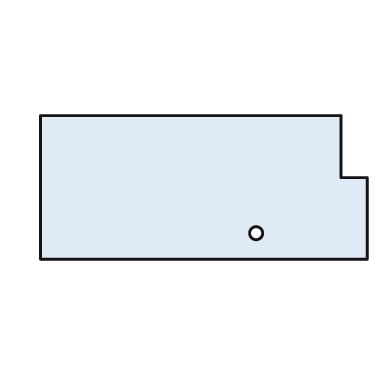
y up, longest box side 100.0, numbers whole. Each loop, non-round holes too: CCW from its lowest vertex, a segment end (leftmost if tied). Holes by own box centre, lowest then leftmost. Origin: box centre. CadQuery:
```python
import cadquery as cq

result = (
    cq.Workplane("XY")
    .moveTo(-50.0, -22.0)
    .lineTo(50.0, -22.0)
    .lineTo(50.0, 3.0)
    .lineTo(42.0, 3.0)
    .lineTo(42.0, 22.0)
    .lineTo(-50.0, 22.0)
    .close()
    .moveTo(16.0, -14.0)
    .circle(2.0)
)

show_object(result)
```